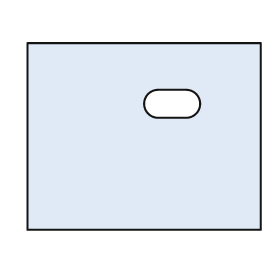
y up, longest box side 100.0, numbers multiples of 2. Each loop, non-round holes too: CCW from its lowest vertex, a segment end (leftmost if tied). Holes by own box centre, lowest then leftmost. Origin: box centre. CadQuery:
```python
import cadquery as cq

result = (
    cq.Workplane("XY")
    .moveTo(-50.0, -40.0)
    .lineTo(50.0, -40.0)
    .lineTo(50.0, 40.0)
    .lineTo(-50.0, 40.0)
    .close()
    .moveTo(6.0, 8.0)
    .lineTo(18.0, 8.0)
    .threePointArc((24.0, 14.0), (18.0, 20.0))
    .lineTo(6.0, 20.0)
    .threePointArc((0.0, 14.0), (6.0, 8.0))
    .close()
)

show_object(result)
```